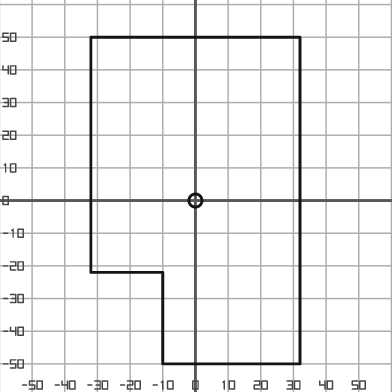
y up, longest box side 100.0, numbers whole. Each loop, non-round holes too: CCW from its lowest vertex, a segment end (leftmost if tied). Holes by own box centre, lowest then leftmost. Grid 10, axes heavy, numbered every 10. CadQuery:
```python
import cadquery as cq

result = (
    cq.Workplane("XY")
    .moveTo(-10.0, -50.0)
    .lineTo(32.0, -50.0)
    .lineTo(32.0, 50.0)
    .lineTo(-32.0, 50.0)
    .lineTo(-32.0, -22.0)
    .lineTo(-10.0, -22.0)
    .close()
    .moveTo(0.0, 0.0)
    .circle(2.0)
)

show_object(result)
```